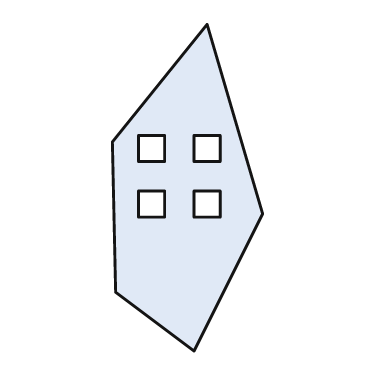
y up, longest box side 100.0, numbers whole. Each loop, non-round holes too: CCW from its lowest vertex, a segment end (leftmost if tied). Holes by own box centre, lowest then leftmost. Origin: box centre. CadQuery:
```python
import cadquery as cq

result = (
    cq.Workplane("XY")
    .moveTo(2.0, -50.0)
    .lineTo(23.0, -8.0)
    .lineTo(6.0, 50.0)
    .lineTo(-23.0, 14.0)
    .lineTo(-22.0, -32.0)
    .close()
    .moveTo(-15.0, -9.0)
    .lineTo(-7.0, -9.0)
    .lineTo(-7.0, -1.0)
    .lineTo(-15.0, -1.0)
    .close()
    .moveTo(2.0, -9.0)
    .lineTo(10.0, -9.0)
    .lineTo(10.0, -1.0)
    .lineTo(2.0, -1.0)
    .close()
    .moveTo(-15.0, 8.0)
    .lineTo(-7.0, 8.0)
    .lineTo(-7.0, 16.0)
    .lineTo(-15.0, 16.0)
    .close()
    .moveTo(2.0, 8.0)
    .lineTo(10.0, 8.0)
    .lineTo(10.0, 16.0)
    .lineTo(2.0, 16.0)
    .close()
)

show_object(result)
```